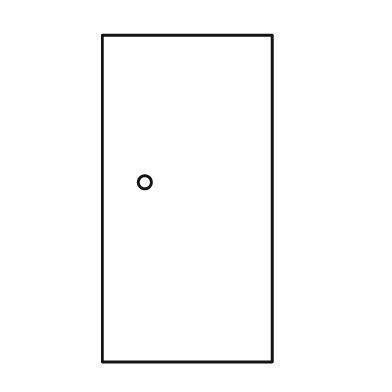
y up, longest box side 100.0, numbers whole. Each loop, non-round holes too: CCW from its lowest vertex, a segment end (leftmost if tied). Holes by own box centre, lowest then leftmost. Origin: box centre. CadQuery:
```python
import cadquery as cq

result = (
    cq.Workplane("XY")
    .moveTo(-26.0, -50.0)
    .lineTo(26.0, -50.0)
    .lineTo(26.0, 50.0)
    .lineTo(-26.0, 50.0)
    .close()
    .moveTo(-13.0, 5.0)
    .circle(2.0)
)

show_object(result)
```